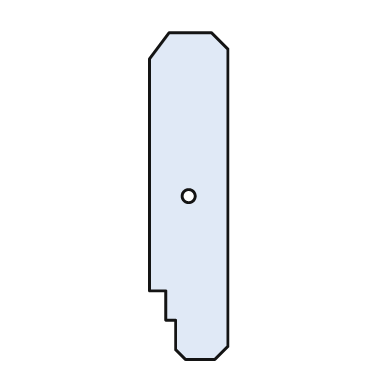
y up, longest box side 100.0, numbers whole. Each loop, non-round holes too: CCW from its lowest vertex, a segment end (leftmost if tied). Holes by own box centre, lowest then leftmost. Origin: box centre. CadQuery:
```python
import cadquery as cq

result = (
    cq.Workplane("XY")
    .moveTo(-1.0, -50.0)
    .lineTo(8.0, -50.0)
    .lineTo(12.0, -46.0)
    .lineTo(12.0, 45.0)
    .lineTo(7.0, 50.0)
    .lineTo(-6.0, 50.0)
    .lineTo(-12.0, 42.0)
    .lineTo(-12.0, -29.0)
    .lineTo(-7.0, -29.0)
    .lineTo(-7.0, -38.0)
    .lineTo(-4.0, -38.0)
    .lineTo(-4.0, -47.0)
    .close()
    .moveTo(0.0, 0.0)
    .circle(2.0)
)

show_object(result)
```